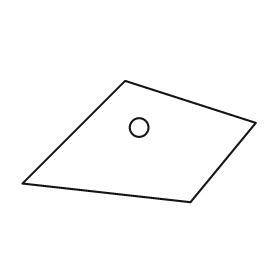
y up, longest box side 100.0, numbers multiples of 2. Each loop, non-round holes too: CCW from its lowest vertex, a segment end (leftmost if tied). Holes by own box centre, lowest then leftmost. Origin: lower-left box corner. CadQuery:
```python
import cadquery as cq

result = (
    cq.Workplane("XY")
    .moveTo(72.0, 0.0)
    .lineTo(100.0, 34.0)
    .lineTo(44.0, 52.0)
    .lineTo(0.0, 8.0)
    .close()
    .moveTo(50.0, 32.0)
    .circle(4.0)
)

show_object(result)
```